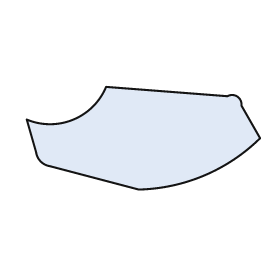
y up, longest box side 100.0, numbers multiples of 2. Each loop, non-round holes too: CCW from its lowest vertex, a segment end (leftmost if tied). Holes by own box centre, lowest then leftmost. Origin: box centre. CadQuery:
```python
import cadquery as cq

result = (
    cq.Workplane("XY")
    .moveTo(-2.0, -22.0)
    .threePointArc((26.0, -16.0), (50.0, 0.0))
    .lineTo(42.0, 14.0)
    .threePointArc((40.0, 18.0), (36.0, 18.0))
    .lineTo(-16.0, 22.0)
    .threePointArc((-30.0, 8.0), (-50.0, 8.0))
    .lineTo(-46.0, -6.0)
    .threePointArc((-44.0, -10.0), (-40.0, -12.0))
    .close()
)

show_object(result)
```